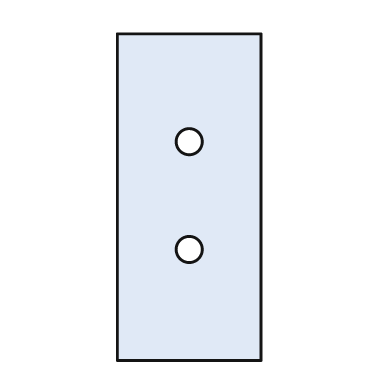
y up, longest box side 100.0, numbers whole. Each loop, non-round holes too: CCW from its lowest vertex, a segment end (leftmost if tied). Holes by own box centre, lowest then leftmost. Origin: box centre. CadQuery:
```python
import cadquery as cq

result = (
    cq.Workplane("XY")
    .moveTo(-22.0, -50.0)
    .lineTo(22.0, -50.0)
    .lineTo(22.0, 50.0)
    .lineTo(-22.0, 50.0)
    .close()
    .moveTo(0.0, -16.0)
    .circle(4.0)
    .moveTo(0.0, 17.0)
    .circle(4.0)
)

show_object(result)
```